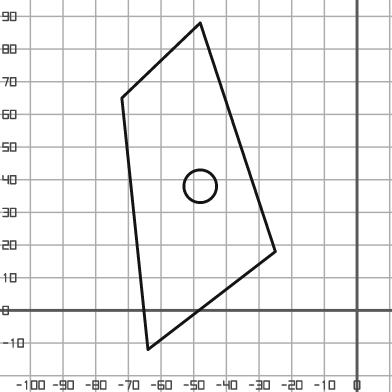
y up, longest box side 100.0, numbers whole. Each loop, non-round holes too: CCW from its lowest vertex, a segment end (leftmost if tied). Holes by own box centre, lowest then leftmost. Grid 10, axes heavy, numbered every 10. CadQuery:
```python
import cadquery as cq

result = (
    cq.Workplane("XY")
    .moveTo(-64.0, -12.0)
    .lineTo(-25.0, 18.0)
    .lineTo(-48.0, 88.0)
    .lineTo(-72.0, 65.0)
    .close()
    .moveTo(-48.0, 38.0)
    .circle(5.0)
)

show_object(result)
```